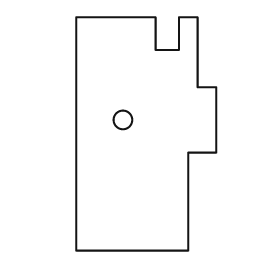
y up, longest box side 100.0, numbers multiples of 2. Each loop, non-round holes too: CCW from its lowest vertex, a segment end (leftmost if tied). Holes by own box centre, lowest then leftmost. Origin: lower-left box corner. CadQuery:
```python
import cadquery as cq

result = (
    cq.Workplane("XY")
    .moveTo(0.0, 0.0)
    .lineTo(48.0, 0.0)
    .lineTo(48.0, 42.0)
    .lineTo(60.0, 42.0)
    .lineTo(60.0, 70.0)
    .lineTo(52.0, 70.0)
    .lineTo(52.0, 100.0)
    .lineTo(44.0, 100.0)
    .lineTo(44.0, 86.0)
    .lineTo(34.0, 86.0)
    .lineTo(34.0, 100.0)
    .lineTo(0.0, 100.0)
    .close()
    .moveTo(20.0, 56.0)
    .circle(4.0)
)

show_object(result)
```